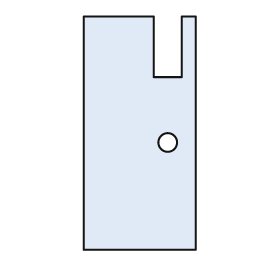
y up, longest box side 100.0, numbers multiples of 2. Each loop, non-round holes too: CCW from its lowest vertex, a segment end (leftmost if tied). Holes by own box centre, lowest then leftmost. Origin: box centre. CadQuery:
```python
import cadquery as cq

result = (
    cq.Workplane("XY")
    .moveTo(-24.0, -50.0)
    .lineTo(24.0, -50.0)
    .lineTo(24.0, 50.0)
    .lineTo(18.0, 50.0)
    .lineTo(18.0, 24.0)
    .lineTo(6.0, 24.0)
    .lineTo(6.0, 50.0)
    .lineTo(-24.0, 50.0)
    .close()
    .moveTo(12.0, -4.0)
    .circle(4.0)
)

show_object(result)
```